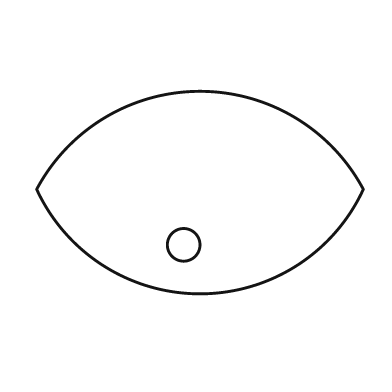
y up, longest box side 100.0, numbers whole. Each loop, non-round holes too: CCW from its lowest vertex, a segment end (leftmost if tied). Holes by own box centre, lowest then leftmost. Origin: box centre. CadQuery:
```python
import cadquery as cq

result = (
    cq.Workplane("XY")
    .moveTo(-50.0, 1.0)
    .threePointArc((0.0, -31.0), (50.0, 1.0))
    .threePointArc((0.0, 31.0), (-50.0, 1.0))
    .close()
    .moveTo(-5.0, -16.0)
    .circle(5.0)
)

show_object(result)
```